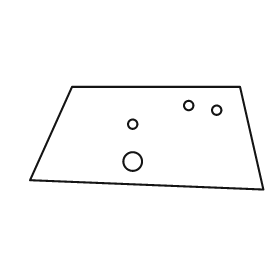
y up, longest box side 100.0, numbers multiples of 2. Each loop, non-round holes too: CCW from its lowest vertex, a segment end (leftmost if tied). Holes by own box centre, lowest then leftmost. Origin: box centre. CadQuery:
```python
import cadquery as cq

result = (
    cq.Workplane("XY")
    .moveTo(50.0, -22.0)
    .lineTo(40.0, 22.0)
    .lineTo(-32.0, 22.0)
    .lineTo(-50.0, -18.0)
    .close()
    .moveTo(-6.0, -10.0)
    .circle(4.0)
    .moveTo(-6.0, 6.0)
    .circle(2.0)
    .moveTo(30.0, 12.0)
    .circle(2.0)
    .moveTo(18.0, 14.0)
    .circle(2.0)
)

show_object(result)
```